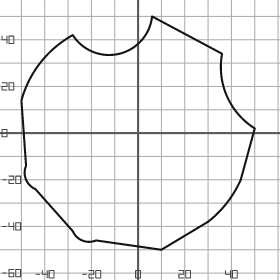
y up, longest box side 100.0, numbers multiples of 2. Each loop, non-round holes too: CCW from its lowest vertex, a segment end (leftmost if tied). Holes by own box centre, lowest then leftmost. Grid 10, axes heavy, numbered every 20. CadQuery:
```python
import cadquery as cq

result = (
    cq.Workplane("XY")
    .moveTo(10.0, -50.0)
    .lineTo(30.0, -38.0)
    .threePointArc((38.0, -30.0), (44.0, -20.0))
    .lineTo(50.0, 2.0)
    .threePointArc((38.0, 16.0), (36.0, 34.0))
    .lineTo(6.0, 50.0)
    .threePointArc((-8.0, 34.0), (-28.0, 42.0))
    .threePointArc((-42.0, 30.0), (-50.0, 14.0))
    .lineTo(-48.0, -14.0)
    .threePointArc((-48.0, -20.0), (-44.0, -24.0))
    .lineTo(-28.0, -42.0)
    .threePointArc((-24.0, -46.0), (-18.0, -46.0))
    .close()
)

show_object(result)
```